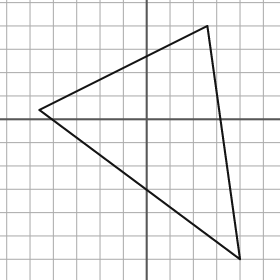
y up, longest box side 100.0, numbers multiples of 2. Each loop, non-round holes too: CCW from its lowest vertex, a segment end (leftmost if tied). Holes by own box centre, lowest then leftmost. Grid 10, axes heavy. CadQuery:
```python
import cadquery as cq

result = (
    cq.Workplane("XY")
    .moveTo(40.0, -60.0)
    .lineTo(26.0, 40.0)
    .lineTo(-46.0, 4.0)
    .close()
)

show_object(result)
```